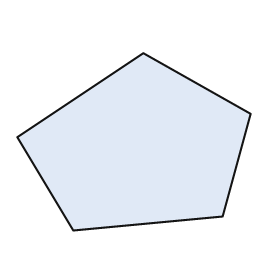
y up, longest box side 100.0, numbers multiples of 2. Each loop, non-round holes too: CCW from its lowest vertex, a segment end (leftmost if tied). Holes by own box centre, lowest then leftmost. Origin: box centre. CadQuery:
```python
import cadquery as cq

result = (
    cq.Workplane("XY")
    .moveTo(-26.0, -38.0)
    .lineTo(38.0, -32.0)
    .lineTo(50.0, 12.0)
    .lineTo(4.0, 38.0)
    .lineTo(-50.0, 2.0)
    .close()
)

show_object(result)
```